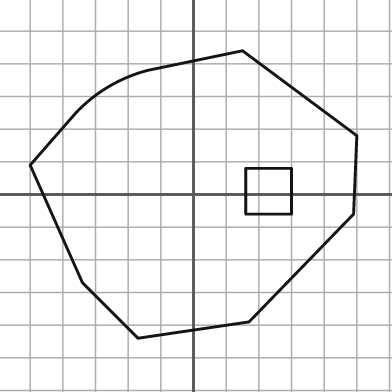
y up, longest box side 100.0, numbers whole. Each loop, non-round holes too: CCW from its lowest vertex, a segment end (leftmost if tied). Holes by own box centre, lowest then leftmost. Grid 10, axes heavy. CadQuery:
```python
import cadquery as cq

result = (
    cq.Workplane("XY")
    .moveTo(-17.0, -44.0)
    .lineTo(17.0, -39.0)
    .lineTo(49.0, -6.0)
    .lineTo(50.0, 18.0)
    .lineTo(15.0, 44.0)
    .lineTo(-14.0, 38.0)
    .threePointArc((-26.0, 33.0), (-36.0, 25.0))
    .lineTo(-50.0, 9.0)
    .lineTo(-34.0, -27.0)
    .close()
    .moveTo(16.0, -6.0)
    .lineTo(30.0, -6.0)
    .lineTo(30.0, 8.0)
    .lineTo(16.0, 8.0)
    .close()
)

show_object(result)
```